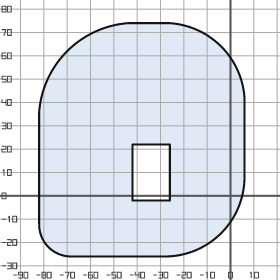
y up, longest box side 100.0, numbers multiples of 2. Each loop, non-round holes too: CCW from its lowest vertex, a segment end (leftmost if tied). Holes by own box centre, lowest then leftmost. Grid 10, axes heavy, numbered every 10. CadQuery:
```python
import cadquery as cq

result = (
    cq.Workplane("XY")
    .moveTo(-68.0, -26.0)
    .lineTo(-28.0, -26.0)
    .threePointArc((-4.0, -16.0), (6.0, 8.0))
    .lineTo(6.0, 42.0)
    .threePointArc((-4.0, 64.0), (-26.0, 74.0))
    .lineTo(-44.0, 74.0)
    .threePointArc((-70.0, 62.0), (-82.0, 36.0))
    .lineTo(-82.0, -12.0)
    .threePointArc((-78.0, -22.0), (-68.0, -26.0))
    .close()
    .moveTo(-42.0, -2.0)
    .lineTo(-26.0, -2.0)
    .lineTo(-26.0, 22.0)
    .lineTo(-42.0, 22.0)
    .close()
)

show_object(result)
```